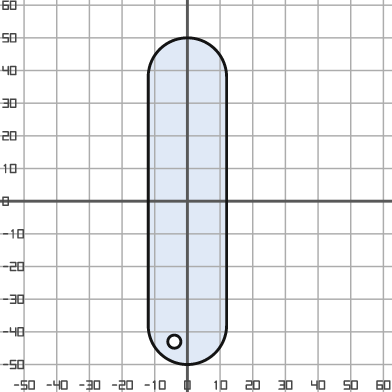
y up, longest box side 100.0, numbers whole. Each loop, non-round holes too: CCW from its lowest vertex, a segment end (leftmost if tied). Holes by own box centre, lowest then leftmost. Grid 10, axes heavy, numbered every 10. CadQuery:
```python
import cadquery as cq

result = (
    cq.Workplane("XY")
    .moveTo(-12.0, -38.0)
    .threePointArc((0.0, -50.0), (12.0, -38.0))
    .lineTo(12.0, 38.0)
    .threePointArc((0.0, 50.0), (-12.0, 38.0))
    .close()
    .moveTo(-4.0, -43.0)
    .circle(2.0)
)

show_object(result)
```